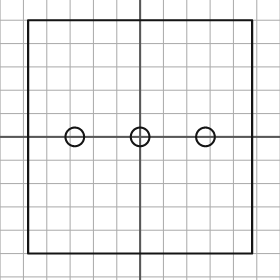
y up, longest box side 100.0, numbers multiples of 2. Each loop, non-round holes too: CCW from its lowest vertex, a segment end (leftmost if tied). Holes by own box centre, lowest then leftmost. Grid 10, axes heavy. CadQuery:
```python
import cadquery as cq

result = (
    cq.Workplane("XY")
    .moveTo(-48.0, -50.0)
    .lineTo(48.0, -50.0)
    .lineTo(48.0, 50.0)
    .lineTo(-48.0, 50.0)
    .close()
    .moveTo(-28.0, 0.0)
    .circle(4.0)
    .moveTo(0.0, 0.0)
    .circle(4.0)
    .moveTo(28.0, 0.0)
    .circle(4.0)
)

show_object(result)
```